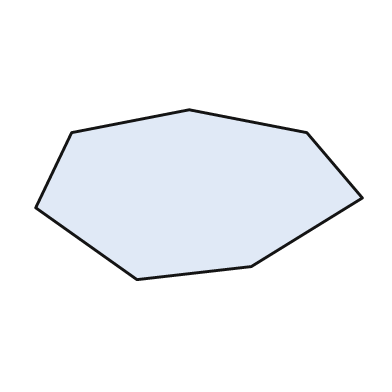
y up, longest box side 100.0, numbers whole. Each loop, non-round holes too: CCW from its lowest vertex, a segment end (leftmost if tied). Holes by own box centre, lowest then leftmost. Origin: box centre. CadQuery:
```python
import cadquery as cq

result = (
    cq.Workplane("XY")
    .moveTo(-19.0, -26.0)
    .lineTo(16.0, -22.0)
    .lineTo(50.0, -1.0)
    .lineTo(33.0, 19.0)
    .lineTo(-3.0, 26.0)
    .lineTo(-39.0, 19.0)
    .lineTo(-50.0, -4.0)
    .close()
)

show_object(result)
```